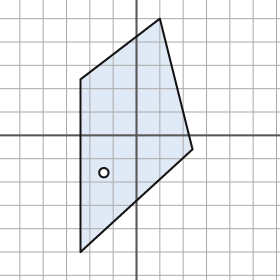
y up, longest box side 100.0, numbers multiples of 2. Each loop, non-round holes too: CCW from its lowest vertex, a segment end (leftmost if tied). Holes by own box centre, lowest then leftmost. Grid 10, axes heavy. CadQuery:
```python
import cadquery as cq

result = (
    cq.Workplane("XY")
    .moveTo(-24.0, -50.0)
    .lineTo(24.0, -6.0)
    .lineTo(10.0, 50.0)
    .lineTo(-24.0, 24.0)
    .close()
    .moveTo(-14.0, -16.0)
    .circle(2.0)
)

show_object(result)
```